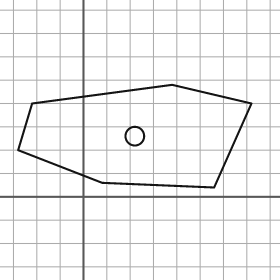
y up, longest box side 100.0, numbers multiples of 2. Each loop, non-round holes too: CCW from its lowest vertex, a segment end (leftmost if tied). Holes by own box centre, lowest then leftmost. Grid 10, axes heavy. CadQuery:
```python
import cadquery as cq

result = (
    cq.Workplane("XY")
    .moveTo(56.0, 4.0)
    .lineTo(72.0, 40.0)
    .lineTo(38.0, 48.0)
    .lineTo(-22.0, 40.0)
    .lineTo(-28.0, 20.0)
    .lineTo(8.0, 6.0)
    .close()
    .moveTo(22.0, 26.0)
    .circle(4.0)
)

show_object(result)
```